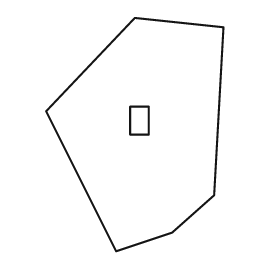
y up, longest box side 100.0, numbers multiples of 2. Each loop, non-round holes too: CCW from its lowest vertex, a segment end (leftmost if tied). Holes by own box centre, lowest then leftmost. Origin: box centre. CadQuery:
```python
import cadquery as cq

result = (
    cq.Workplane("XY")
    .moveTo(-8.0, -50.0)
    .lineTo(16.0, -42.0)
    .lineTo(34.0, -26.0)
    .lineTo(38.0, 46.0)
    .lineTo(0.0, 50.0)
    .lineTo(-38.0, 10.0)
    .close()
    .moveTo(-2.0, 0.0)
    .lineTo(6.0, 0.0)
    .lineTo(6.0, 12.0)
    .lineTo(-2.0, 12.0)
    .close()
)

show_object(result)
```